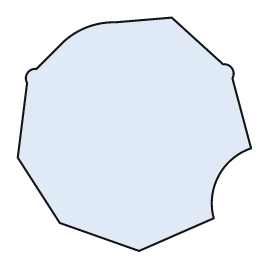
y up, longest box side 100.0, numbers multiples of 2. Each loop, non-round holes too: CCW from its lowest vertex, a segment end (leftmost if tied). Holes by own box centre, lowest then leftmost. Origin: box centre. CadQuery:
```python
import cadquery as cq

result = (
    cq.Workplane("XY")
    .moveTo(2.0, -50.0)
    .lineTo(34.0, -36.0)
    .threePointArc((36.0, -18.0), (50.0, -6.0))
    .lineTo(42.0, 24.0)
    .threePointArc((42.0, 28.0), (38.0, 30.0))
    .lineTo(16.0, 50.0)
    .lineTo(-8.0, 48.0)
    .threePointArc((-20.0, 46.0), (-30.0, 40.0))
    .lineTo(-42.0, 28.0)
    .threePointArc((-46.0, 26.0), (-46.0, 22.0))
    .lineTo(-50.0, -10.0)
    .lineTo(-32.0, -38.0)
    .close()
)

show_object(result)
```